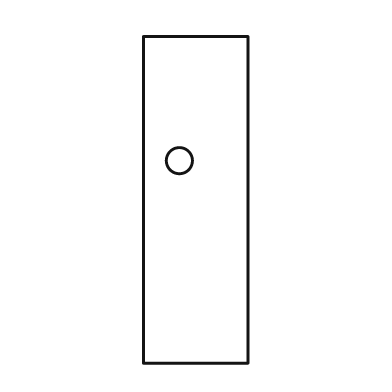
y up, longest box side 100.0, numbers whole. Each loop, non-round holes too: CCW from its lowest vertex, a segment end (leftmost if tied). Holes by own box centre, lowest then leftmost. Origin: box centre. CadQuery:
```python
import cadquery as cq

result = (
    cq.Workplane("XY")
    .moveTo(-16.0, -50.0)
    .lineTo(16.0, -50.0)
    .lineTo(16.0, 50.0)
    .lineTo(-16.0, 50.0)
    .close()
    .moveTo(-5.0, 12.0)
    .circle(4.0)
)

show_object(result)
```